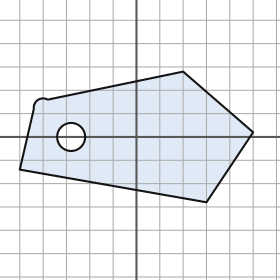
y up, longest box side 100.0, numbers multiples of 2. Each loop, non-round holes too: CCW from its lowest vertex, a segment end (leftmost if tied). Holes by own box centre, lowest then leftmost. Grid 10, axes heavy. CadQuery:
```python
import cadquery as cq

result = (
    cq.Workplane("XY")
    .moveTo(30.0, -28.0)
    .lineTo(50.0, 2.0)
    .lineTo(20.0, 28.0)
    .lineTo(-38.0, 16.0)
    .threePointArc((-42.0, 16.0), (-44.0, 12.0))
    .lineTo(-50.0, -14.0)
    .close()
    .moveTo(-28.0, 0.0)
    .circle(6.0)
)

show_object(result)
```